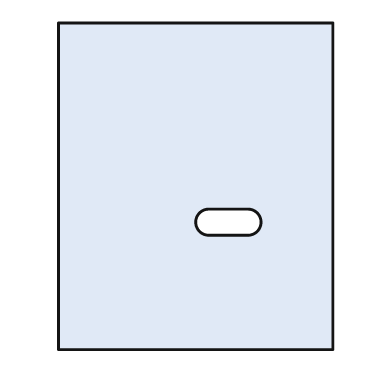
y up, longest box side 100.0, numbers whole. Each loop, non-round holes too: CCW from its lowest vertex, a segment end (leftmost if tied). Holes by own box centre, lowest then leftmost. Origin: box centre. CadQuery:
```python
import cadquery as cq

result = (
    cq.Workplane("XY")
    .moveTo(-42.0, -50.0)
    .lineTo(42.0, -50.0)
    .lineTo(42.0, 50.0)
    .lineTo(-42.0, 50.0)
    .close()
    .moveTo(4.0, -15.0)
    .lineTo(16.0, -15.0)
    .threePointArc((20.0, -11.0), (16.0, -7.0))
    .lineTo(4.0, -7.0)
    .threePointArc((0.0, -11.0), (4.0, -15.0))
    .close()
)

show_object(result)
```